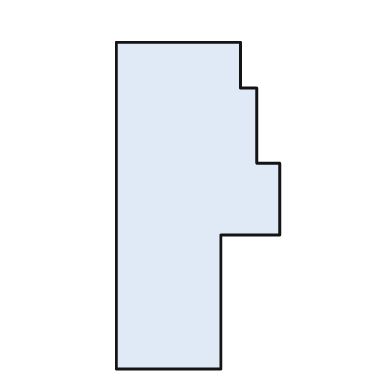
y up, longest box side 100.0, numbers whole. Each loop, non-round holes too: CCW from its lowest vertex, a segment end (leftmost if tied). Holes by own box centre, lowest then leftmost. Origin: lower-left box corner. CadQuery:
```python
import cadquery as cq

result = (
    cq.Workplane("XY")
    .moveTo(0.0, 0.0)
    .lineTo(32.0, 0.0)
    .lineTo(32.0, 41.0)
    .lineTo(50.0, 41.0)
    .lineTo(50.0, 63.0)
    .lineTo(43.0, 63.0)
    .lineTo(43.0, 86.0)
    .lineTo(38.0, 86.0)
    .lineTo(38.0, 100.0)
    .lineTo(0.0, 100.0)
    .close()
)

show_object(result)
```